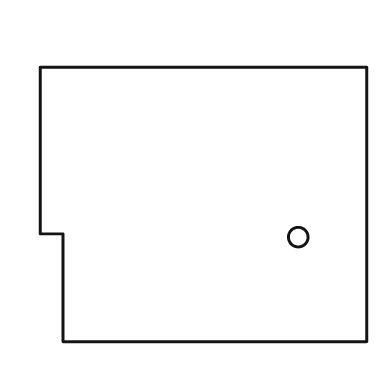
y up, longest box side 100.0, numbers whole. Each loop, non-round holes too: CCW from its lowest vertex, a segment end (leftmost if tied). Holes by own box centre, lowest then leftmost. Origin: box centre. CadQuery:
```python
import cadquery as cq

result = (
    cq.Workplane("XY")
    .moveTo(-43.0, -42.0)
    .lineTo(50.0, -42.0)
    .lineTo(50.0, 42.0)
    .lineTo(-50.0, 42.0)
    .lineTo(-50.0, -9.0)
    .lineTo(-43.0, -9.0)
    .close()
    .moveTo(29.0, -10.0)
    .circle(3.0)
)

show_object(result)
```